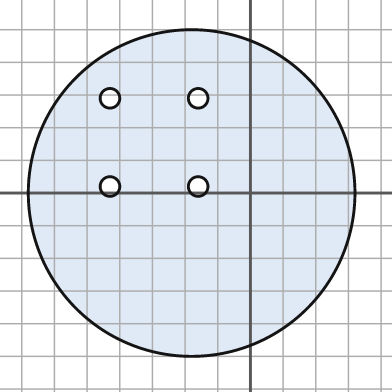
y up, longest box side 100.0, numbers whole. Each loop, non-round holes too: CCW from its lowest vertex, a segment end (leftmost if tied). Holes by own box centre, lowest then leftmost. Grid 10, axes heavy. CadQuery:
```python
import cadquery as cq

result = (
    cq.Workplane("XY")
    .moveTo(-18.0, 0.0)
    .circle(50.0)
    .moveTo(-43.0, 2.0)
    .circle(3.0)
    .moveTo(-16.0, 2.0)
    .circle(3.0)
    .moveTo(-43.0, 29.0)
    .circle(3.0)
    .moveTo(-16.0, 29.0)
    .circle(3.0)
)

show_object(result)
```